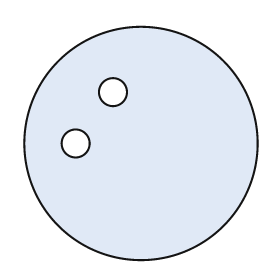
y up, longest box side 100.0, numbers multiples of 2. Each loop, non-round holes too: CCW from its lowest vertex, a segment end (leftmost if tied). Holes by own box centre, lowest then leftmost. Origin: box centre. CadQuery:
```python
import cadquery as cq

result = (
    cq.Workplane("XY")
    .moveTo(0.0, 0.0)
    .circle(50.0)
    .moveTo(-28.0, 0.0)
    .circle(6.0)
    .moveTo(-12.0, 22.0)
    .circle(6.0)
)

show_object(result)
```